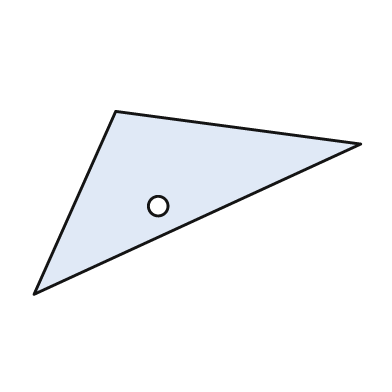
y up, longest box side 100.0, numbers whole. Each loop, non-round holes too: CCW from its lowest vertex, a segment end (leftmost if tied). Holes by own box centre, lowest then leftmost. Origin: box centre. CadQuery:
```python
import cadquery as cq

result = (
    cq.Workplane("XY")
    .moveTo(-50.0, -28.0)
    .lineTo(50.0, 18.0)
    .lineTo(-25.0, 28.0)
    .close()
    .moveTo(-12.0, -1.0)
    .circle(3.0)
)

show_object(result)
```